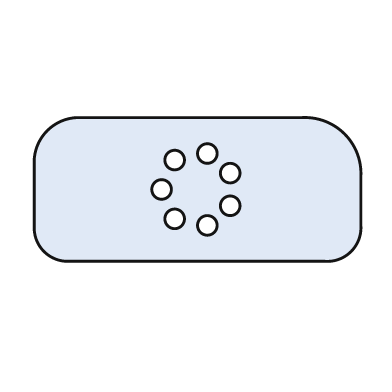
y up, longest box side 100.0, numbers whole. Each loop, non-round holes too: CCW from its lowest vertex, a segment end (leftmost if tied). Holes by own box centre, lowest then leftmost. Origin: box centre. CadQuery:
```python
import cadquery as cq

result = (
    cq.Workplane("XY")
    .moveTo(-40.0, -22.0)
    .lineTo(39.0, -22.0)
    .threePointArc((47.0, -19.0), (50.0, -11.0))
    .lineTo(50.0, 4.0)
    .threePointArc((45.0, 17.0), (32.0, 22.0))
    .lineTo(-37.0, 22.0)
    .threePointArc((-46.0, 18.0), (-50.0, 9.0))
    .lineTo(-50.0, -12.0)
    .threePointArc((-47.0, -19.0), (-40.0, -22.0))
    .close()
    .moveTo(3.0, -11.0)
    .circle(3.0)
    .moveTo(-7.0, -9.0)
    .circle(3.0)
    .moveTo(10.0, -5.0)
    .circle(3.0)
    .moveTo(-11.0, 0.0)
    .circle(3.0)
    .moveTo(10.0, 5.0)
    .circle(3.0)
    .moveTo(-7.0, 9.0)
    .circle(3.0)
    .moveTo(3.0, 11.0)
    .circle(3.0)
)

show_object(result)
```